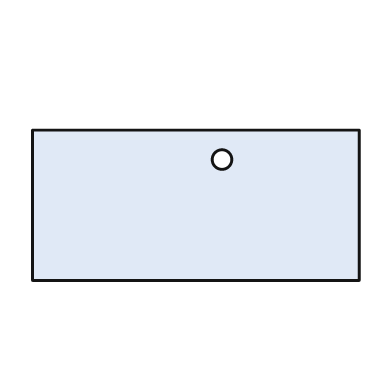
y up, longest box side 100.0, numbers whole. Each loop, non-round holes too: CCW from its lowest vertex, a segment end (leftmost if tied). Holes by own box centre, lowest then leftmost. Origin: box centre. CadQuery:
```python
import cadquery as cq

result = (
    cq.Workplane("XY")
    .moveTo(-50.0, -23.0)
    .lineTo(50.0, -23.0)
    .lineTo(50.0, 23.0)
    .lineTo(-50.0, 23.0)
    .close()
    .moveTo(8.0, 14.0)
    .circle(3.0)
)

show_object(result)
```